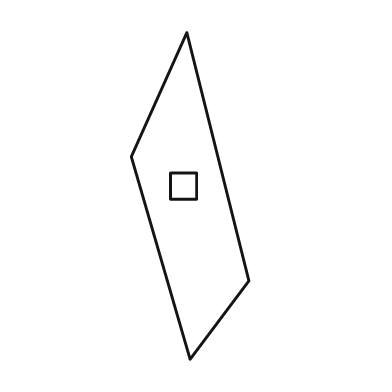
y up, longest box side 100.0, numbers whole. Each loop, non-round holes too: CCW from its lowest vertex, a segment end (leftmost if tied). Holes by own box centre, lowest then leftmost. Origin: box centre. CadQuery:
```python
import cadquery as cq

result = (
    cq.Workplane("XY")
    .moveTo(0.0, -50.0)
    .lineTo(18.0, -26.0)
    .lineTo(-1.0, 50.0)
    .lineTo(-18.0, 12.0)
    .close()
    .moveTo(-6.0, -1.0)
    .lineTo(2.0, -1.0)
    .lineTo(2.0, 7.0)
    .lineTo(-6.0, 7.0)
    .close()
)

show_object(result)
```